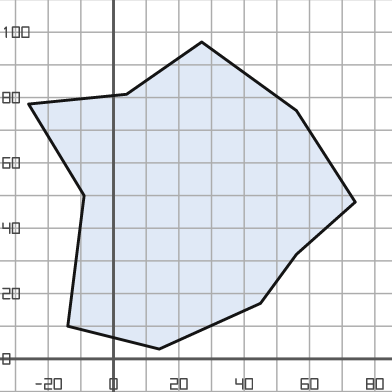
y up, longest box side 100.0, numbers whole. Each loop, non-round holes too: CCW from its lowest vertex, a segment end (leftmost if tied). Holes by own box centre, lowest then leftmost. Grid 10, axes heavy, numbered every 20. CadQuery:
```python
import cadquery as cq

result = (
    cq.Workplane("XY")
    .moveTo(14.0, 3.0)
    .lineTo(45.0, 17.0)
    .lineTo(56.0, 32.0)
    .lineTo(74.0, 48.0)
    .lineTo(56.0, 76.0)
    .lineTo(27.0, 97.0)
    .lineTo(4.0, 81.0)
    .lineTo(-26.0, 78.0)
    .lineTo(-9.0, 50.0)
    .lineTo(-14.0, 10.0)
    .close()
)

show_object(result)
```